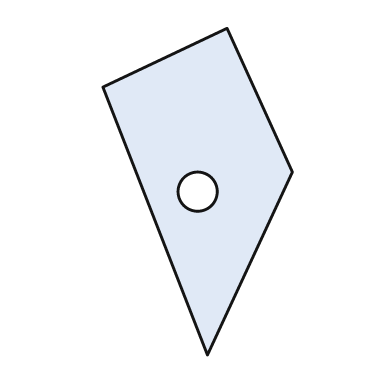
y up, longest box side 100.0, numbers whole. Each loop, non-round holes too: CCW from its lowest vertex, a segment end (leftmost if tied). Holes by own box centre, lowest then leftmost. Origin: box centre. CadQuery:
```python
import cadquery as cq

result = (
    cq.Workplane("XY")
    .moveTo(3.0, -50.0)
    .lineTo(29.0, 6.0)
    .lineTo(9.0, 50.0)
    .lineTo(-29.0, 32.0)
    .close()
    .moveTo(0.0, 0.0)
    .circle(6.0)
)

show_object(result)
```